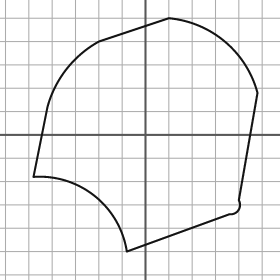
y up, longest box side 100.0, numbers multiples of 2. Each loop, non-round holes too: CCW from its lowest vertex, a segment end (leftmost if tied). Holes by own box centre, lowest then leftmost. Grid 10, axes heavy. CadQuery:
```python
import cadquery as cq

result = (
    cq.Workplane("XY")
    .moveTo(-8.0, -50.0)
    .lineTo(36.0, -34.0)
    .threePointArc((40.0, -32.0), (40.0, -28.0))
    .lineTo(48.0, 18.0)
    .threePointArc((34.0, 40.0), (10.0, 50.0))
    .lineTo(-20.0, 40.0)
    .threePointArc((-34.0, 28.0), (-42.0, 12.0))
    .lineTo(-48.0, -18.0)
    .threePointArc((-22.0, -26.0), (-8.0, -50.0))
    .close()
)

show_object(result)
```